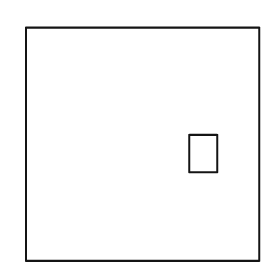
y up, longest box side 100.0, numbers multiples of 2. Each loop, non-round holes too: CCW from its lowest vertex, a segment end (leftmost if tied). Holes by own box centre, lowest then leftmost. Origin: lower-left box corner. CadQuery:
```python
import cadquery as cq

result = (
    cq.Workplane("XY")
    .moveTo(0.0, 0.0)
    .lineTo(100.0, 0.0)
    .lineTo(100.0, 100.0)
    .lineTo(0.0, 100.0)
    .close()
    .moveTo(70.0, 38.0)
    .lineTo(82.0, 38.0)
    .lineTo(82.0, 54.0)
    .lineTo(70.0, 54.0)
    .close()
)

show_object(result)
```